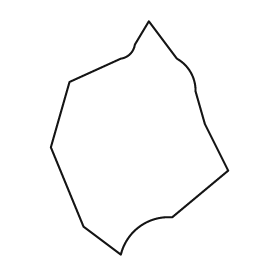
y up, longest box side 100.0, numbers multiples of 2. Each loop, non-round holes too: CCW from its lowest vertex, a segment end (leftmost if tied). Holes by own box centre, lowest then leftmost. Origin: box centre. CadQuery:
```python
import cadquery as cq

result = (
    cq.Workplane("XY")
    .moveTo(-8.0, -50.0)
    .threePointArc((0.0, -38.0), (14.0, -34.0))
    .lineTo(38.0, -14.0)
    .lineTo(28.0, 6.0)
    .lineTo(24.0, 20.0)
    .threePointArc((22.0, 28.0), (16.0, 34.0))
    .lineTo(4.0, 50.0)
    .lineTo(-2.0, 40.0)
    .threePointArc((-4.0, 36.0), (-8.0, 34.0))
    .lineTo(-30.0, 24.0)
    .lineTo(-38.0, -4.0)
    .lineTo(-24.0, -38.0)
    .close()
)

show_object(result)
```